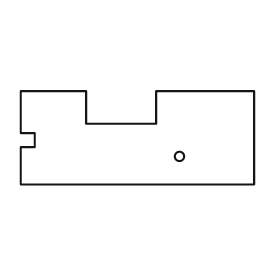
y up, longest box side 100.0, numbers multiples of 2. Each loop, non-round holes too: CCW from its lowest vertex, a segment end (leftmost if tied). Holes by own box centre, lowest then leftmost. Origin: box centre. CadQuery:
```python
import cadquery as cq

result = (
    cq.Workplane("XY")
    .moveTo(-50.0, -20.0)
    .lineTo(50.0, -20.0)
    .lineTo(50.0, 20.0)
    .lineTo(8.0, 20.0)
    .lineTo(8.0, 6.0)
    .lineTo(-22.0, 6.0)
    .lineTo(-22.0, 20.0)
    .lineTo(-50.0, 20.0)
    .lineTo(-50.0, 2.0)
    .lineTo(-44.0, 2.0)
    .lineTo(-44.0, -4.0)
    .lineTo(-50.0, -4.0)
    .close()
    .moveTo(18.0, -8.0)
    .circle(2.0)
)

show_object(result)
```